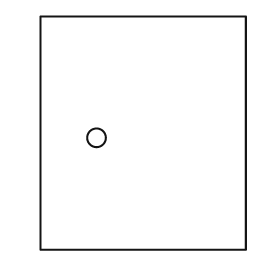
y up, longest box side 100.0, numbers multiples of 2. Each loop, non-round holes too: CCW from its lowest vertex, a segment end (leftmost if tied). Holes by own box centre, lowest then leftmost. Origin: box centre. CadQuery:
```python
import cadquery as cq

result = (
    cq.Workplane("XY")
    .moveTo(-44.0, -50.0)
    .lineTo(44.0, -50.0)
    .lineTo(44.0, 50.0)
    .lineTo(-44.0, 50.0)
    .close()
    .moveTo(-20.0, -2.0)
    .circle(4.0)
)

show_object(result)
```